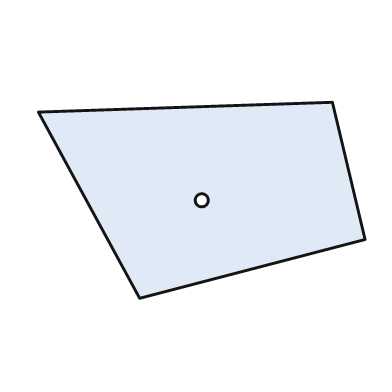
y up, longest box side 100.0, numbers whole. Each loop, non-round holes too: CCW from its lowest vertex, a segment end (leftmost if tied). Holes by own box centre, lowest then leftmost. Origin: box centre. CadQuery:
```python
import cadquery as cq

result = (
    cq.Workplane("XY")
    .moveTo(-19.0, -30.0)
    .lineTo(50.0, -12.0)
    .lineTo(40.0, 30.0)
    .lineTo(-50.0, 27.0)
    .close()
    .moveTo(0.0, 0.0)
    .circle(2.0)
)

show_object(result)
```